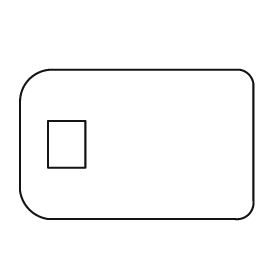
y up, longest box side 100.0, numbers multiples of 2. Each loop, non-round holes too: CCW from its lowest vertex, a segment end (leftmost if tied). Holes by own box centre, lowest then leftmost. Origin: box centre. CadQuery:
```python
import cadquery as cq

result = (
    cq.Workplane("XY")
    .moveTo(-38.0, -32.0)
    .lineTo(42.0, -32.0)
    .threePointArc((48.0, -30.0), (50.0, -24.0))
    .lineTo(50.0, 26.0)
    .threePointArc((48.0, 30.0), (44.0, 32.0))
    .lineTo(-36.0, 32.0)
    .threePointArc((-46.0, 28.0), (-50.0, 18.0))
    .lineTo(-50.0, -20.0)
    .threePointArc((-46.0, -28.0), (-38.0, -32.0))
    .close()
    .moveTo(-38.0, -10.0)
    .lineTo(-22.0, -10.0)
    .lineTo(-22.0, 10.0)
    .lineTo(-38.0, 10.0)
    .close()
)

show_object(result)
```